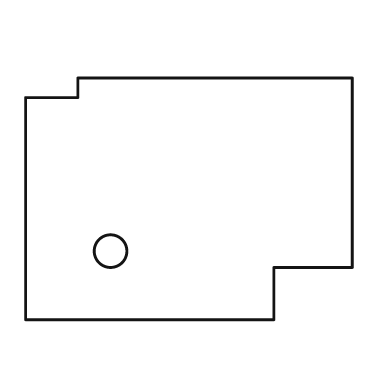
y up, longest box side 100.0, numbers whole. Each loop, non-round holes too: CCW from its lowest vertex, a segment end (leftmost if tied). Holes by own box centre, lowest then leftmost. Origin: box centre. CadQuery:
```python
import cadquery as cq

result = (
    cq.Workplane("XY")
    .moveTo(-50.0, -37.0)
    .lineTo(26.0, -37.0)
    .lineTo(26.0, -21.0)
    .lineTo(50.0, -21.0)
    .lineTo(50.0, 37.0)
    .lineTo(-34.0, 37.0)
    .lineTo(-34.0, 31.0)
    .lineTo(-50.0, 31.0)
    .close()
    .moveTo(-24.0, -16.0)
    .circle(5.0)
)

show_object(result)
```